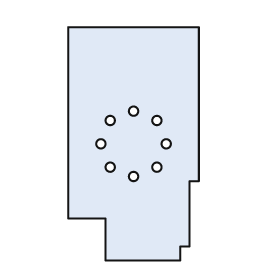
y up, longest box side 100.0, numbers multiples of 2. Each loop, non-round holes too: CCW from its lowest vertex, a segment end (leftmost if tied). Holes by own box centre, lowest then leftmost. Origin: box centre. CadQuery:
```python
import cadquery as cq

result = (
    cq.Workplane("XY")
    .moveTo(-12.0, -50.0)
    .lineTo(20.0, -50.0)
    .lineTo(20.0, -44.0)
    .lineTo(24.0, -44.0)
    .lineTo(24.0, -16.0)
    .lineTo(28.0, -16.0)
    .lineTo(28.0, 50.0)
    .lineTo(-28.0, 50.0)
    .lineTo(-28.0, -32.0)
    .lineTo(-12.0, -32.0)
    .close()
    .moveTo(0.0, -14.0)
    .circle(2.0)
    .moveTo(-10.0, -10.0)
    .circle(2.0)
    .moveTo(10.0, -10.0)
    .circle(2.0)
    .moveTo(-14.0, 0.0)
    .circle(2.0)
    .moveTo(14.0, 0.0)
    .circle(2.0)
    .moveTo(-10.0, 10.0)
    .circle(2.0)
    .moveTo(10.0, 10.0)
    .circle(2.0)
    .moveTo(0.0, 14.0)
    .circle(2.0)
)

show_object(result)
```